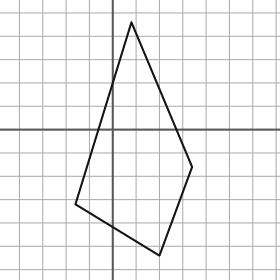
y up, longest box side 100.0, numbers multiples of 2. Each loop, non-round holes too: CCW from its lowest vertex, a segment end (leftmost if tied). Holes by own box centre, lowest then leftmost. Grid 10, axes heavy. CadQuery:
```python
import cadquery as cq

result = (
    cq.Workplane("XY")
    .moveTo(20.0, -54.0)
    .lineTo(34.0, -16.0)
    .lineTo(8.0, 46.0)
    .lineTo(-16.0, -32.0)
    .close()
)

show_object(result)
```